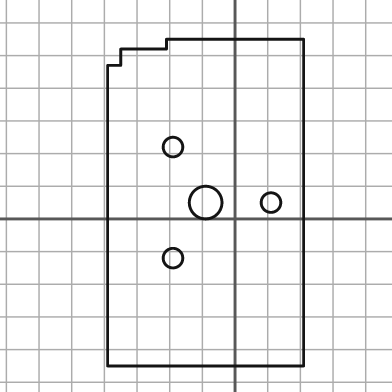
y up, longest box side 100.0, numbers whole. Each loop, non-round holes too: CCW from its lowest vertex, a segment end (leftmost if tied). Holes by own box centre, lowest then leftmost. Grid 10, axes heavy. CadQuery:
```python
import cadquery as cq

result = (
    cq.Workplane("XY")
    .moveTo(-39.0, -45.0)
    .lineTo(21.0, -45.0)
    .lineTo(21.0, 55.0)
    .lineTo(-21.0, 55.0)
    .lineTo(-21.0, 52.0)
    .lineTo(-35.0, 52.0)
    .lineTo(-35.0, 47.0)
    .lineTo(-39.0, 47.0)
    .close()
    .moveTo(-19.0, -12.0)
    .circle(3.0)
    .moveTo(-9.0, 5.0)
    .circle(5.0)
    .moveTo(11.0, 5.0)
    .circle(3.0)
    .moveTo(-19.0, 22.0)
    .circle(3.0)
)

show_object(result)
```